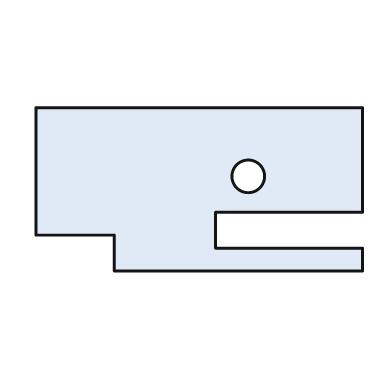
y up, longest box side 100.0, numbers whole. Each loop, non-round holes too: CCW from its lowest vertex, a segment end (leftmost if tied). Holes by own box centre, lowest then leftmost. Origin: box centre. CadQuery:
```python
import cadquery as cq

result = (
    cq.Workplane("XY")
    .moveTo(-26.0, -25.0)
    .lineTo(50.0, -25.0)
    .lineTo(50.0, -18.0)
    .lineTo(5.0, -18.0)
    .lineTo(5.0, -7.0)
    .lineTo(50.0, -7.0)
    .lineTo(50.0, 25.0)
    .lineTo(-50.0, 25.0)
    .lineTo(-50.0, -14.0)
    .lineTo(-26.0, -14.0)
    .close()
    .moveTo(15.0, 4.0)
    .circle(5.0)
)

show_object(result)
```